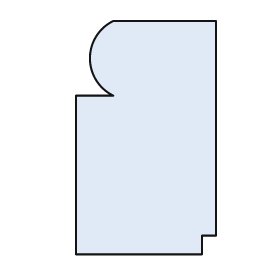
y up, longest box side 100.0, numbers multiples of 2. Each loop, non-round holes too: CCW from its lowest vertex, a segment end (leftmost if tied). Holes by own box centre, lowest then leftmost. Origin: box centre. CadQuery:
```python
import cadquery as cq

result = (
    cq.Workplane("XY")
    .moveTo(-30.0, -50.0)
    .lineTo(24.0, -50.0)
    .lineTo(24.0, -42.0)
    .lineTo(30.0, -42.0)
    .lineTo(30.0, 50.0)
    .lineTo(-14.0, 50.0)
    .threePointArc((-24.0, 34.0), (-14.0, 18.0))
    .lineTo(-30.0, 18.0)
    .close()
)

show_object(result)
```